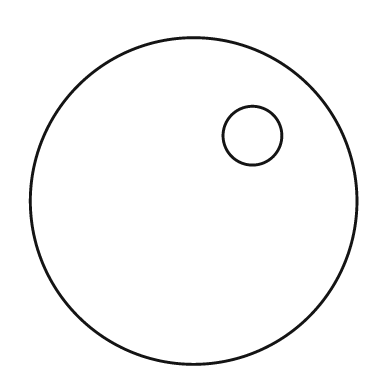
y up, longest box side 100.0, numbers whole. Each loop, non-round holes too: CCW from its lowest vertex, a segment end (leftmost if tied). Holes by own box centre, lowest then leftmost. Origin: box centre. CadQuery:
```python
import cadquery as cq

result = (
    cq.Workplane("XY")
    .moveTo(0.0, 0.0)
    .circle(50.0)
    .moveTo(18.0, 20.0)
    .circle(9.0)
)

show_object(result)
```